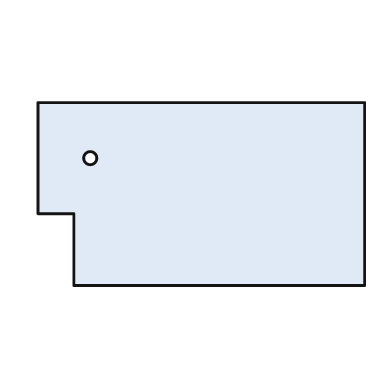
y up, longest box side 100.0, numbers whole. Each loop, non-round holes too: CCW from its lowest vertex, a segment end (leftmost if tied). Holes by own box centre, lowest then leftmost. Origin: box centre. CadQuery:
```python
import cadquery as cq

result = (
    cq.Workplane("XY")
    .moveTo(-39.0, -28.0)
    .lineTo(50.0, -28.0)
    .lineTo(50.0, 28.0)
    .lineTo(-50.0, 28.0)
    .lineTo(-50.0, -6.0)
    .lineTo(-39.0, -6.0)
    .close()
    .moveTo(-34.0, 11.0)
    .circle(2.0)
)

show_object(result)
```